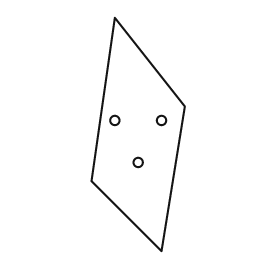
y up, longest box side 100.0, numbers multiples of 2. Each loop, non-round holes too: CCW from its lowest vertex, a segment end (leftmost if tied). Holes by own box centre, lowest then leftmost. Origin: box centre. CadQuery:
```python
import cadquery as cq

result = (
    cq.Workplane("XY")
    .moveTo(10.0, -50.0)
    .lineTo(20.0, 12.0)
    .lineTo(-10.0, 50.0)
    .lineTo(-20.0, -20.0)
    .close()
    .moveTo(0.0, -12.0)
    .circle(2.0)
    .moveTo(-10.0, 6.0)
    .circle(2.0)
    .moveTo(10.0, 6.0)
    .circle(2.0)
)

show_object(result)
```